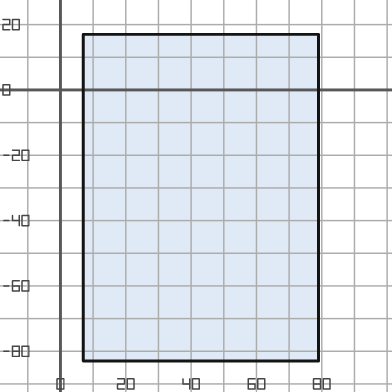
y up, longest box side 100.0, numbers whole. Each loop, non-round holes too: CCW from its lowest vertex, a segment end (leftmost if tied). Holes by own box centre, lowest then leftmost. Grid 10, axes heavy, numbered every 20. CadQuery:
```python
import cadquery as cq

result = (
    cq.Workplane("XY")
    .moveTo(7.0, -83.0)
    .lineTo(79.0, -83.0)
    .lineTo(79.0, 17.0)
    .lineTo(7.0, 17.0)
    .close()
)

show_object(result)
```